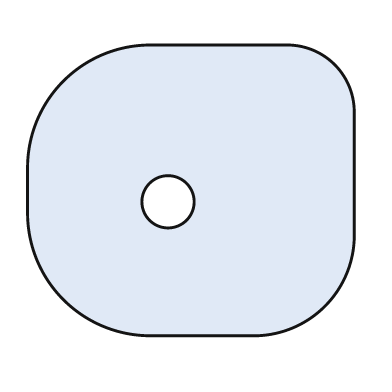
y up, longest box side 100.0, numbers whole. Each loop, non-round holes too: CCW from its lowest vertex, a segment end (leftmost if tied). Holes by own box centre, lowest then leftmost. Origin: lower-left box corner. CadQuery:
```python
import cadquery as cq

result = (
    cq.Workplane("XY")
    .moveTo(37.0, 0.0)
    .lineTo(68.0, 0.0)
    .threePointArc((91.0, 9.0), (100.0, 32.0))
    .lineTo(100.0, 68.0)
    .threePointArc((94.0, 83.0), (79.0, 89.0))
    .lineTo(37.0, 89.0)
    .threePointArc((11.0, 78.0), (0.0, 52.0))
    .lineTo(0.0, 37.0)
    .threePointArc((11.0, 11.0), (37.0, 0.0))
    .close()
    .moveTo(43.0, 41.0)
    .circle(8.0)
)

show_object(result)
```